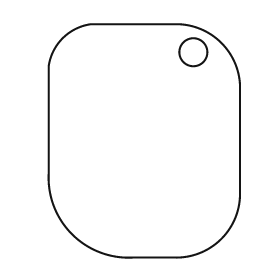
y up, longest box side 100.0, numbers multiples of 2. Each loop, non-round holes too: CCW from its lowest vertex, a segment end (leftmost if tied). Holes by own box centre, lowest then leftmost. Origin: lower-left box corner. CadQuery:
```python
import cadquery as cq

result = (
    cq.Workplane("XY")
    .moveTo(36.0, 0.0)
    .lineTo(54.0, 0.0)
    .threePointArc((74.0, 8.0), (82.0, 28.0))
    .lineTo(82.0, 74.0)
    .threePointArc((74.0, 92.0), (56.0, 100.0))
    .lineTo(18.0, 100.0)
    .threePointArc((6.0, 94.0), (0.0, 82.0))
    .lineTo(0.0, 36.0)
    .threePointArc((10.0, 10.0), (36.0, 0.0))
    .close()
    .moveTo(62.0, 88.0)
    .circle(6.0)
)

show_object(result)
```